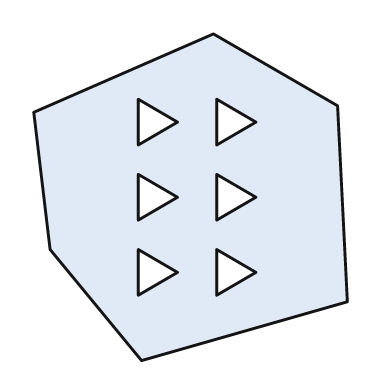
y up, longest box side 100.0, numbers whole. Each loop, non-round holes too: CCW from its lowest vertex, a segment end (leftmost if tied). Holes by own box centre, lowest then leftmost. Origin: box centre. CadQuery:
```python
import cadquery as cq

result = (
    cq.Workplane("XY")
    .moveTo(-15.0, -50.0)
    .lineTo(48.0, -32.0)
    .lineTo(45.0, 28.0)
    .lineTo(7.0, 50.0)
    .lineTo(-48.0, 26.0)
    .lineTo(-43.0, -16.0)
    .close()
    .moveTo(-16.0, -30.0)
    .lineTo(-4.0, -23.0)
    .lineTo(-16.0, -16.0)
    .close()
    .moveTo(8.0, -30.0)
    .lineTo(20.0, -23.0)
    .lineTo(8.0, -16.0)
    .close()
    .moveTo(-16.0, -7.0)
    .lineTo(-4.0, 0.0)
    .lineTo(-16.0, 7.0)
    .close()
    .moveTo(8.0, -7.0)
    .lineTo(20.0, 0.0)
    .lineTo(8.0, 7.0)
    .close()
    .moveTo(-16.0, 16.0)
    .lineTo(-4.0, 23.0)
    .lineTo(-16.0, 30.0)
    .close()
    .moveTo(8.0, 16.0)
    .lineTo(20.0, 23.0)
    .lineTo(8.0, 30.0)
    .close()
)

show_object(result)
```